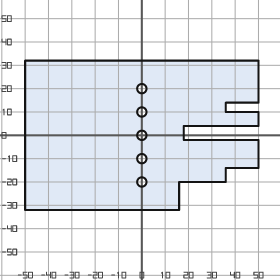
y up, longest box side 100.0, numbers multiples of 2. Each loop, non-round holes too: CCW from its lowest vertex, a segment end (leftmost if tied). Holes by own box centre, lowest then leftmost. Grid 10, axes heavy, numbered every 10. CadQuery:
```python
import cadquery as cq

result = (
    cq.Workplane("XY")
    .moveTo(-50.0, -32.0)
    .lineTo(16.0, -32.0)
    .lineTo(16.0, -20.0)
    .lineTo(36.0, -20.0)
    .lineTo(36.0, -14.0)
    .lineTo(50.0, -14.0)
    .lineTo(50.0, -2.0)
    .lineTo(18.0, -2.0)
    .lineTo(18.0, 4.0)
    .lineTo(50.0, 4.0)
    .lineTo(50.0, 10.0)
    .lineTo(36.0, 10.0)
    .lineTo(36.0, 14.0)
    .lineTo(50.0, 14.0)
    .lineTo(50.0, 32.0)
    .lineTo(-50.0, 32.0)
    .close()
    .moveTo(0.0, -20.0)
    .circle(2.0)
    .moveTo(0.0, -10.0)
    .circle(2.0)
    .moveTo(0.0, 0.0)
    .circle(2.0)
    .moveTo(0.0, 10.0)
    .circle(2.0)
    .moveTo(0.0, 20.0)
    .circle(2.0)
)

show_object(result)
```